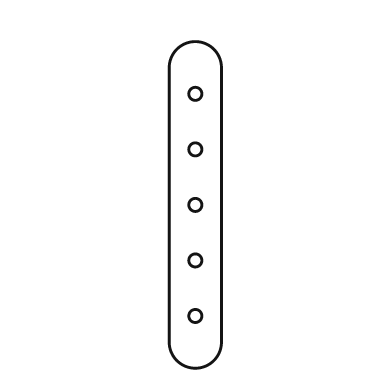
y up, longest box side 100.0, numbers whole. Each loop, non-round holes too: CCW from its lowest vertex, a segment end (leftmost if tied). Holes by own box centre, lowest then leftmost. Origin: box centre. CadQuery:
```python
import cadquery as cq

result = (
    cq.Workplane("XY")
    .moveTo(-8.0, -42.0)
    .threePointArc((0.0, -50.0), (8.0, -42.0))
    .lineTo(8.0, 42.0)
    .threePointArc((0.0, 50.0), (-8.0, 42.0))
    .close()
    .moveTo(0.0, -34.0)
    .circle(2.0)
    .moveTo(0.0, -17.0)
    .circle(2.0)
    .moveTo(0.0, 0.0)
    .circle(2.0)
    .moveTo(0.0, 17.0)
    .circle(2.0)
    .moveTo(0.0, 34.0)
    .circle(2.0)
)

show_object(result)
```